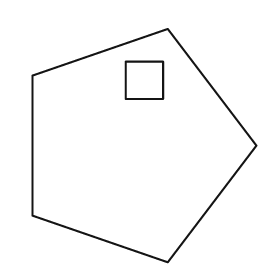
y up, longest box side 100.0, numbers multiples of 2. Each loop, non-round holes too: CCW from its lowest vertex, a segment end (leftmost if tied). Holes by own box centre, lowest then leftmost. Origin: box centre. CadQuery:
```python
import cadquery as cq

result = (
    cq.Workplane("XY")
    .moveTo(10.0, -50.0)
    .lineTo(48.0, 0.0)
    .lineTo(10.0, 50.0)
    .lineTo(-48.0, 30.0)
    .lineTo(-48.0, -30.0)
    .close()
    .moveTo(-8.0, 20.0)
    .lineTo(8.0, 20.0)
    .lineTo(8.0, 36.0)
    .lineTo(-8.0, 36.0)
    .close()
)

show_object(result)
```